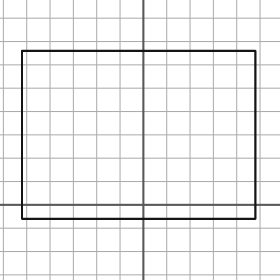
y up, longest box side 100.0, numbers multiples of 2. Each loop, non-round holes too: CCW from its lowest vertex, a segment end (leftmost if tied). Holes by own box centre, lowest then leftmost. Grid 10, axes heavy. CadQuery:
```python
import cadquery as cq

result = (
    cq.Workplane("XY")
    .moveTo(-52.0, -6.0)
    .lineTo(48.0, -6.0)
    .lineTo(48.0, 66.0)
    .lineTo(-52.0, 66.0)
    .close()
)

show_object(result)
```